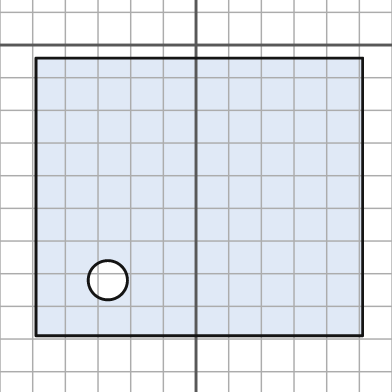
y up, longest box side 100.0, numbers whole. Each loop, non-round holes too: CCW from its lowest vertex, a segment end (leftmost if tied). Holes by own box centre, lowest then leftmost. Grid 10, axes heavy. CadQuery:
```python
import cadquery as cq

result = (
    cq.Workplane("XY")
    .moveTo(-49.0, -89.0)
    .lineTo(51.0, -89.0)
    .lineTo(51.0, -4.0)
    .lineTo(-49.0, -4.0)
    .close()
    .moveTo(-27.0, -72.0)
    .circle(6.0)
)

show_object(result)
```